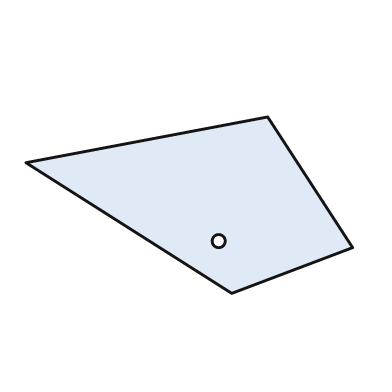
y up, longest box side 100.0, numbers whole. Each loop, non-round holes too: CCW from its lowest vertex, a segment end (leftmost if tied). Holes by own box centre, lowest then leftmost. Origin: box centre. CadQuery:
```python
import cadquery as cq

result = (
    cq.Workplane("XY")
    .moveTo(13.0, -27.0)
    .lineTo(50.0, -13.0)
    .lineTo(24.0, 27.0)
    .lineTo(-50.0, 13.0)
    .close()
    .moveTo(9.0, -11.0)
    .circle(2.0)
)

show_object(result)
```